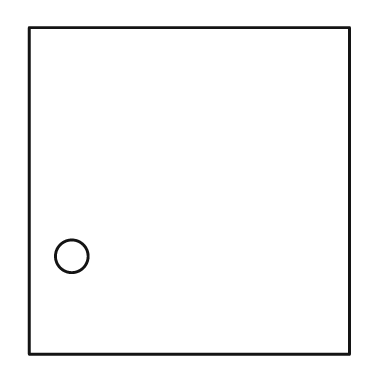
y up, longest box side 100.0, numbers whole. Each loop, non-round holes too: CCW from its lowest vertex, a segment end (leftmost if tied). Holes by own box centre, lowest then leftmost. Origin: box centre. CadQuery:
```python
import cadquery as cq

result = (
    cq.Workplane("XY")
    .moveTo(-49.0, -50.0)
    .lineTo(49.0, -50.0)
    .lineTo(49.0, 50.0)
    .lineTo(-49.0, 50.0)
    .close()
    .moveTo(-36.0, -20.0)
    .circle(5.0)
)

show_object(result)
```